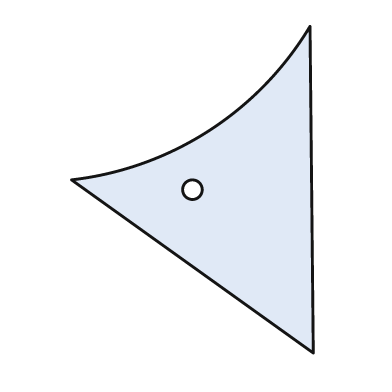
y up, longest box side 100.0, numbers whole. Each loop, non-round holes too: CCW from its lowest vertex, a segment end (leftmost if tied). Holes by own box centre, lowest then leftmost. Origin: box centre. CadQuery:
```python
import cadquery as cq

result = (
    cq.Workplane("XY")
    .moveTo(37.0, -50.0)
    .lineTo(36.0, 50.0)
    .threePointArc((5.0, 18.0), (-37.0, 3.0))
    .close()
    .moveTo(0.0, 0.0)
    .circle(3.0)
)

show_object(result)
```